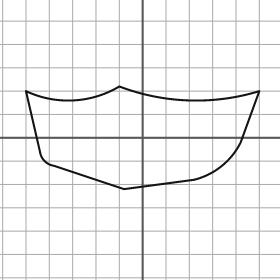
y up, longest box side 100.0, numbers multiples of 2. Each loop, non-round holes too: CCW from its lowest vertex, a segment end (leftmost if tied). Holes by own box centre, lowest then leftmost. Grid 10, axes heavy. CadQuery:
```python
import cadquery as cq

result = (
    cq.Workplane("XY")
    .moveTo(-8.0, -22.0)
    .lineTo(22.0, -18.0)
    .threePointArc((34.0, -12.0), (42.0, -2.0))
    .lineTo(50.0, 20.0)
    .threePointArc((20.0, 16.0), (-10.0, 22.0))
    .threePointArc((-30.0, 16.0), (-50.0, 20.0))
    .lineTo(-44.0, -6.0)
    .threePointArc((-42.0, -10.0), (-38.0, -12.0))
    .close()
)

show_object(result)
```